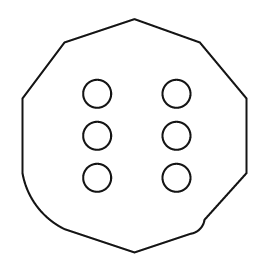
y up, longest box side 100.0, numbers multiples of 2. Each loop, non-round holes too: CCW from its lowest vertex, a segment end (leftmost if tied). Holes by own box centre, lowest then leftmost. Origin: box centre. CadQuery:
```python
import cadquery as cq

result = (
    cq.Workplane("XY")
    .moveTo(0.0, -50.0)
    .lineTo(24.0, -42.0)
    .threePointArc((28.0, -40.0), (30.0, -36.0))
    .lineTo(48.0, -16.0)
    .lineTo(48.0, 16.0)
    .lineTo(28.0, 40.0)
    .lineTo(0.0, 50.0)
    .lineTo(-30.0, 40.0)
    .lineTo(-48.0, 16.0)
    .lineTo(-48.0, -16.0)
    .threePointArc((-42.0, -30.0), (-30.0, -40.0))
    .close()
    .moveTo(-16.0, -18.0)
    .circle(6.0)
    .moveTo(18.0, -18.0)
    .circle(6.0)
    .moveTo(-16.0, 0.0)
    .circle(6.0)
    .moveTo(18.0, 0.0)
    .circle(6.0)
    .moveTo(-16.0, 18.0)
    .circle(6.0)
    .moveTo(18.0, 18.0)
    .circle(6.0)
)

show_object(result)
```